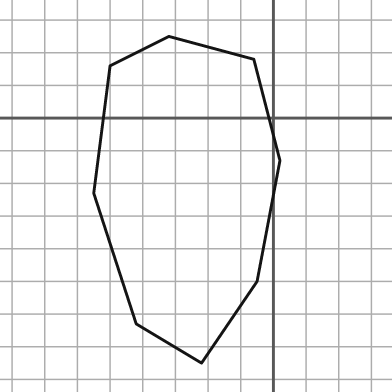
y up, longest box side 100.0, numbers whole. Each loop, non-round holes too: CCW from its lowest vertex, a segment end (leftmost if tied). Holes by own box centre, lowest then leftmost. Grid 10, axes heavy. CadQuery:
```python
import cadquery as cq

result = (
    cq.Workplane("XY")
    .moveTo(-22.0, -75.0)
    .lineTo(-5.0, -50.0)
    .lineTo(2.0, -13.0)
    .lineTo(-6.0, 18.0)
    .lineTo(-32.0, 25.0)
    .lineTo(-50.0, 16.0)
    .lineTo(-55.0, -23.0)
    .lineTo(-42.0, -63.0)
    .close()
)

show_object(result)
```